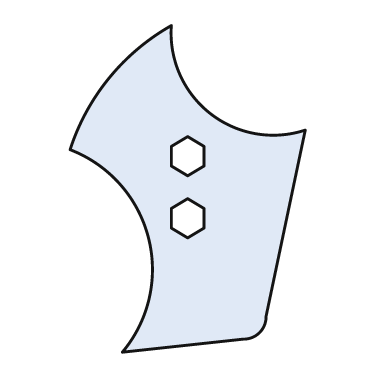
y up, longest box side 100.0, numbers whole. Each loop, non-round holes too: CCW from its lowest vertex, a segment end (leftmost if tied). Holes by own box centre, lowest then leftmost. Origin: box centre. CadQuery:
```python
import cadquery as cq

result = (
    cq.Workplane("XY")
    .moveTo(-20.0, -50.0)
    .lineTo(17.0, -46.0)
    .threePointArc((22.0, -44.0), (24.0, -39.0))
    .lineTo(36.0, 18.0)
    .threePointArc((7.0, 23.0), (-5.0, 50.0))
    .threePointArc((-24.0, 34.0), (-36.0, 12.0))
    .threePointArc((-12.0, -15.0), (-20.0, -50.0))
    .close()
    .moveTo(0.0, -15.0)
    .lineTo(5.0, -12.0)
    .lineTo(5.0, -6.0)
    .lineTo(0.0, -3.0)
    .lineTo(-5.0, -6.0)
    .lineTo(-5.0, -12.0)
    .close()
    .moveTo(0.0, 4.0)
    .lineTo(5.0, 7.0)
    .lineTo(5.0, 13.0)
    .lineTo(0.0, 16.0)
    .lineTo(-5.0, 13.0)
    .lineTo(-5.0, 7.0)
    .close()
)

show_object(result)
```